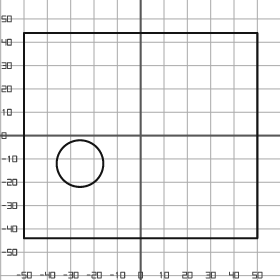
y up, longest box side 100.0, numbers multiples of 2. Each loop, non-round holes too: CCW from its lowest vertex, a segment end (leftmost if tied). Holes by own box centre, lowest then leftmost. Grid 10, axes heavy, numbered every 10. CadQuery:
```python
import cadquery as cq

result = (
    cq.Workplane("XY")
    .moveTo(-50.0, -44.0)
    .lineTo(50.0, -44.0)
    .lineTo(50.0, 44.0)
    .lineTo(-50.0, 44.0)
    .close()
    .moveTo(-26.0, -12.0)
    .circle(10.0)
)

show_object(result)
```